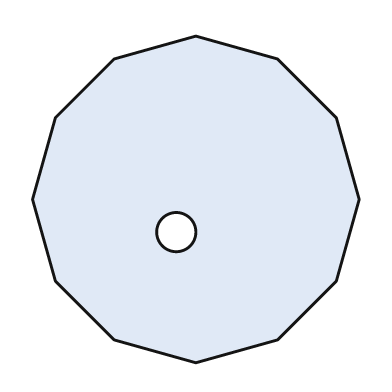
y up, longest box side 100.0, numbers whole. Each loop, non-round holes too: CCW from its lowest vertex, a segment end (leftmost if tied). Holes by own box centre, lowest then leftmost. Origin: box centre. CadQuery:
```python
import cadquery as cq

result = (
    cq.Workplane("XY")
    .moveTo(0.0, -50.0)
    .lineTo(25.0, -43.0)
    .lineTo(43.0, -25.0)
    .lineTo(50.0, 0.0)
    .lineTo(43.0, 25.0)
    .lineTo(25.0, 43.0)
    .lineTo(0.0, 50.0)
    .lineTo(-25.0, 43.0)
    .lineTo(-43.0, 25.0)
    .lineTo(-50.0, 0.0)
    .lineTo(-43.0, -25.0)
    .lineTo(-25.0, -43.0)
    .close()
    .moveTo(-6.0, -10.0)
    .circle(6.0)
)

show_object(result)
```